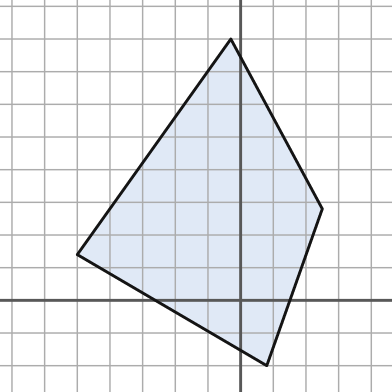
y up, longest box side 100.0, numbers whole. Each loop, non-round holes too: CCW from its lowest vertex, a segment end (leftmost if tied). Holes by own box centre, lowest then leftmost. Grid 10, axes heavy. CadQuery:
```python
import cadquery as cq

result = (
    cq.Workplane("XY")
    .moveTo(8.0, -20.0)
    .lineTo(25.0, 28.0)
    .lineTo(-3.0, 80.0)
    .lineTo(-50.0, 14.0)
    .close()
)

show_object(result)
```